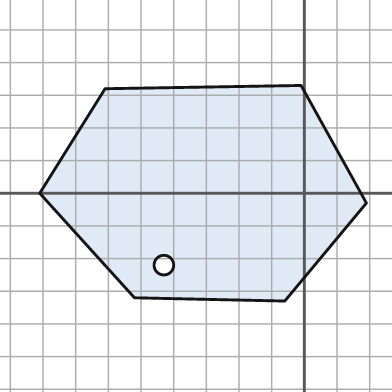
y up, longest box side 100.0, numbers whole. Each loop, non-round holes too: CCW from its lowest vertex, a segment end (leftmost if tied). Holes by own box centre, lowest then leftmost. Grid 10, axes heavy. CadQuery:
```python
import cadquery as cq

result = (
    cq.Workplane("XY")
    .moveTo(-6.0, -33.0)
    .lineTo(19.0, -3.0)
    .lineTo(-1.0, 33.0)
    .lineTo(-61.0, 32.0)
    .lineTo(-81.0, 0.0)
    .lineTo(-52.0, -32.0)
    .close()
    .moveTo(-43.0, -22.0)
    .circle(3.0)
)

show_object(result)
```